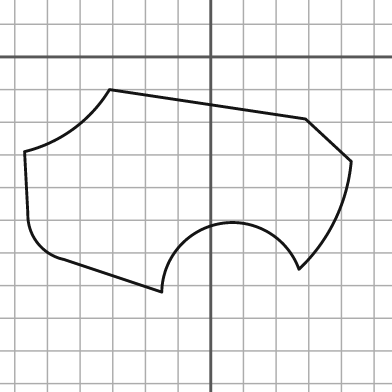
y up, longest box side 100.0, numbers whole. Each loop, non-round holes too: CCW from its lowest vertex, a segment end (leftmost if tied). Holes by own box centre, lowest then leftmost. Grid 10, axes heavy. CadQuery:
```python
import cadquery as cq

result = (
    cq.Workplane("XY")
    .moveTo(-15.0, -72.0)
    .threePointArc((3.0, -51.0), (27.0, -65.0))
    .threePointArc((38.0, -50.0), (43.0, -32.0))
    .lineTo(29.0, -19.0)
    .lineTo(-31.0, -10.0)
    .threePointArc((-42.0, -22.0), (-57.0, -29.0))
    .lineTo(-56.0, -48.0)
    .threePointArc((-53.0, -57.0), (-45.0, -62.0))
    .close()
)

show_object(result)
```